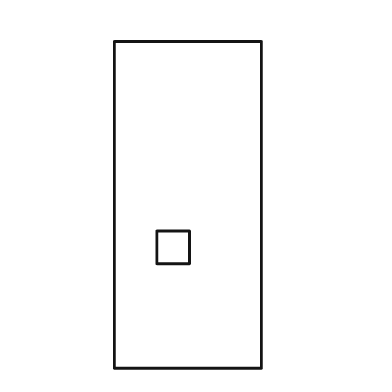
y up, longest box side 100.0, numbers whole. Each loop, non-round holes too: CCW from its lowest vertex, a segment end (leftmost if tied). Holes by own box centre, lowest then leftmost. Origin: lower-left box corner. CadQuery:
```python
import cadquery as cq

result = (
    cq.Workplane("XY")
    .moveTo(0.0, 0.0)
    .lineTo(45.0, 0.0)
    .lineTo(45.0, 100.0)
    .lineTo(0.0, 100.0)
    .close()
    .moveTo(13.0, 32.0)
    .lineTo(23.0, 32.0)
    .lineTo(23.0, 42.0)
    .lineTo(13.0, 42.0)
    .close()
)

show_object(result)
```